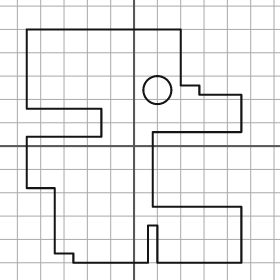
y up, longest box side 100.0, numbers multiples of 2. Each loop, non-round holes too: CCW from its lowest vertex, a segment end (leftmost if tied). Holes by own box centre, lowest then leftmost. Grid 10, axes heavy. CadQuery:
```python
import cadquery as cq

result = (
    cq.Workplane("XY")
    .moveTo(-26.0, -50.0)
    .lineTo(6.0, -50.0)
    .lineTo(6.0, -34.0)
    .lineTo(10.0, -34.0)
    .lineTo(10.0, -50.0)
    .lineTo(46.0, -50.0)
    .lineTo(46.0, -26.0)
    .lineTo(8.0, -26.0)
    .lineTo(8.0, 6.0)
    .lineTo(46.0, 6.0)
    .lineTo(46.0, 22.0)
    .lineTo(28.0, 22.0)
    .lineTo(28.0, 26.0)
    .lineTo(20.0, 26.0)
    .lineTo(20.0, 50.0)
    .lineTo(-46.0, 50.0)
    .lineTo(-46.0, 16.0)
    .lineTo(-14.0, 16.0)
    .lineTo(-14.0, 4.0)
    .lineTo(-46.0, 4.0)
    .lineTo(-46.0, -18.0)
    .lineTo(-34.0, -18.0)
    .lineTo(-34.0, -46.0)
    .lineTo(-26.0, -46.0)
    .close()
    .moveTo(10.0, 24.0)
    .circle(6.0)
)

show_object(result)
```